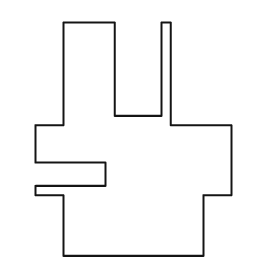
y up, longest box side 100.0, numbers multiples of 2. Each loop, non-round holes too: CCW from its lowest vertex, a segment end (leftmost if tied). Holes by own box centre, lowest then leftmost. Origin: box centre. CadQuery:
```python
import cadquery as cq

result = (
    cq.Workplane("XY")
    .moveTo(-30.0, -50.0)
    .lineTo(30.0, -50.0)
    .lineTo(30.0, -24.0)
    .lineTo(42.0, -24.0)
    .lineTo(42.0, 6.0)
    .lineTo(16.0, 6.0)
    .lineTo(16.0, 50.0)
    .lineTo(12.0, 50.0)
    .lineTo(12.0, 10.0)
    .lineTo(-8.0, 10.0)
    .lineTo(-8.0, 50.0)
    .lineTo(-30.0, 50.0)
    .lineTo(-30.0, 6.0)
    .lineTo(-42.0, 6.0)
    .lineTo(-42.0, -10.0)
    .lineTo(-12.0, -10.0)
    .lineTo(-12.0, -20.0)
    .lineTo(-42.0, -20.0)
    .lineTo(-42.0, -24.0)
    .lineTo(-30.0, -24.0)
    .close()
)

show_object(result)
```